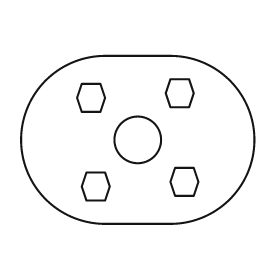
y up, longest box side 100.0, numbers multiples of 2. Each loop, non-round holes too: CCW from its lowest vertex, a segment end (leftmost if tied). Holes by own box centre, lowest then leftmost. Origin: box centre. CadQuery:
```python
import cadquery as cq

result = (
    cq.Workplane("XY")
    .moveTo(-14.0, -36.0)
    .lineTo(14.0, -36.0)
    .threePointArc((50.0, 0.0), (14.0, 36.0))
    .lineTo(-14.0, 36.0)
    .threePointArc((-50.0, 0.0), (-14.0, -36.0))
    .close()
    .moveTo(-22.0, -26.0)
    .lineTo(-14.0, -26.0)
    .lineTo(-12.0, -20.0)
    .lineTo(-14.0, -14.0)
    .lineTo(-22.0, -14.0)
    .lineTo(-24.0, -20.0)
    .close()
    .moveTo(16.0, -24.0)
    .lineTo(24.0, -24.0)
    .lineTo(26.0, -18.0)
    .lineTo(24.0, -12.0)
    .lineTo(16.0, -12.0)
    .lineTo(14.0, -18.0)
    .close()
    .moveTo(0.0, 0.0)
    .circle(10.0)
    .moveTo(-24.0, 12.0)
    .lineTo(-16.0, 12.0)
    .lineTo(-14.0, 18.0)
    .lineTo(-16.0, 24.0)
    .lineTo(-24.0, 24.0)
    .lineTo(-26.0, 18.0)
    .close()
    .moveTo(14.0, 14.0)
    .lineTo(22.0, 14.0)
    .lineTo(24.0, 20.0)
    .lineTo(22.0, 26.0)
    .lineTo(14.0, 26.0)
    .lineTo(12.0, 20.0)
    .close()
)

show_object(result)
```